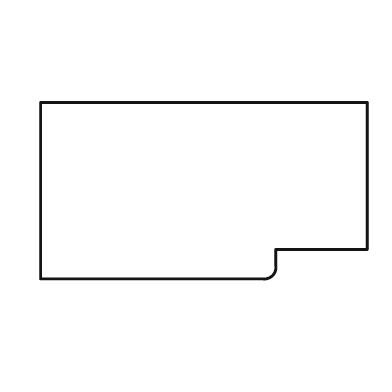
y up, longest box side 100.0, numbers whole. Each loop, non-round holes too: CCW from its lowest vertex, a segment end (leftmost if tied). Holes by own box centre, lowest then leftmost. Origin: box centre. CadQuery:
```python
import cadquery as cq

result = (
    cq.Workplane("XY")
    .moveTo(-50.0, -27.0)
    .lineTo(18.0, -27.0)
    .threePointArc((21.0, -26.0), (22.0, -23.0))
    .lineTo(22.0, -18.0)
    .lineTo(50.0, -18.0)
    .lineTo(50.0, 27.0)
    .lineTo(-50.0, 27.0)
    .close()
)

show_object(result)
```